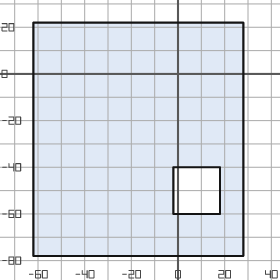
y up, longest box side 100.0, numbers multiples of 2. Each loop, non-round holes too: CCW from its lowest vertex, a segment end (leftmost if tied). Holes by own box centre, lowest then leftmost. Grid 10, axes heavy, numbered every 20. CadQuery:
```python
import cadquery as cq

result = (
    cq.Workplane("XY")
    .moveTo(-62.0, -78.0)
    .lineTo(28.0, -78.0)
    .lineTo(28.0, 22.0)
    .lineTo(-62.0, 22.0)
    .close()
    .moveTo(-2.0, -60.0)
    .lineTo(18.0, -60.0)
    .lineTo(18.0, -40.0)
    .lineTo(-2.0, -40.0)
    .close()
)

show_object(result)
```